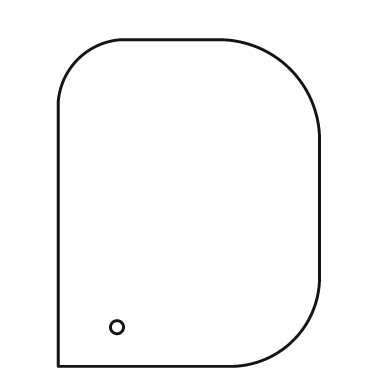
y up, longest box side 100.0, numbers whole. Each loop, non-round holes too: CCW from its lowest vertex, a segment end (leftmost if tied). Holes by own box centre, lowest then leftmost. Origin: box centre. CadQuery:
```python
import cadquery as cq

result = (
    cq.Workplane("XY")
    .moveTo(-40.0, -50.0)
    .lineTo(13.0, -50.0)
    .threePointArc((32.0, -42.0), (40.0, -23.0))
    .lineTo(40.0, 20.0)
    .threePointArc((31.0, 41.0), (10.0, 50.0))
    .lineTo(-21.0, 50.0)
    .threePointArc((-34.0, 44.0), (-40.0, 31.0))
    .close()
    .moveTo(-22.0, -38.0)
    .circle(2.0)
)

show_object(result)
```